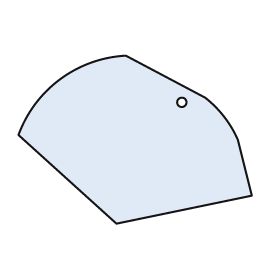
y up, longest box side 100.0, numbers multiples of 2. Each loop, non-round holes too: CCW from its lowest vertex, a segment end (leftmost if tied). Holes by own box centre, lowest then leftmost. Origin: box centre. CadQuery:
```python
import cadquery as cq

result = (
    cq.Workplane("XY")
    .moveTo(-8.0, -36.0)
    .lineTo(50.0, -24.0)
    .lineTo(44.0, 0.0)
    .threePointArc((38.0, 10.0), (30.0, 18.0))
    .lineTo(-4.0, 36.0)
    .threePointArc((-32.0, 26.0), (-50.0, 2.0))
    .close()
    .moveTo(20.0, 16.0)
    .circle(2.0)
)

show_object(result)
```